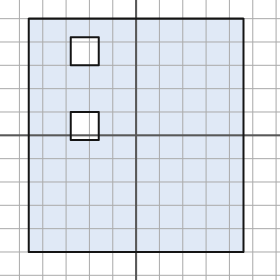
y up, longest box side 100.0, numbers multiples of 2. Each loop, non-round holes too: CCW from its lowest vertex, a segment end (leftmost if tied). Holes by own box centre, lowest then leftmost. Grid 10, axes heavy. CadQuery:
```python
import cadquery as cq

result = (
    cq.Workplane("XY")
    .moveTo(-46.0, -50.0)
    .lineTo(46.0, -50.0)
    .lineTo(46.0, 50.0)
    .lineTo(-46.0, 50.0)
    .close()
    .moveTo(-28.0, -2.0)
    .lineTo(-16.0, -2.0)
    .lineTo(-16.0, 10.0)
    .lineTo(-28.0, 10.0)
    .close()
    .moveTo(-28.0, 30.0)
    .lineTo(-16.0, 30.0)
    .lineTo(-16.0, 42.0)
    .lineTo(-28.0, 42.0)
    .close()
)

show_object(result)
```